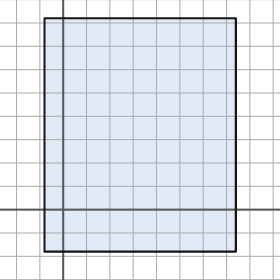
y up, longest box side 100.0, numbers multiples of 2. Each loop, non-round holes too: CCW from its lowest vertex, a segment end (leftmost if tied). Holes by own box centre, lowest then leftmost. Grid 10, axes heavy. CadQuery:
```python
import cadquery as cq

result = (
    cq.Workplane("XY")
    .moveTo(-8.0, -18.0)
    .lineTo(74.0, -18.0)
    .lineTo(74.0, 82.0)
    .lineTo(-8.0, 82.0)
    .close()
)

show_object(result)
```